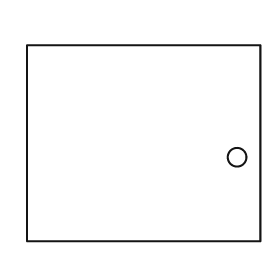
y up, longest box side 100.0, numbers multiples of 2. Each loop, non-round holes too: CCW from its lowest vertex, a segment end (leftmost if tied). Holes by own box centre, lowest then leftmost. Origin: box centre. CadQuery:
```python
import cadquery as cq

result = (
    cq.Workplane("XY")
    .moveTo(-50.0, -42.0)
    .lineTo(50.0, -42.0)
    .lineTo(50.0, 42.0)
    .lineTo(-50.0, 42.0)
    .close()
    .moveTo(40.0, -6.0)
    .circle(4.0)
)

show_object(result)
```